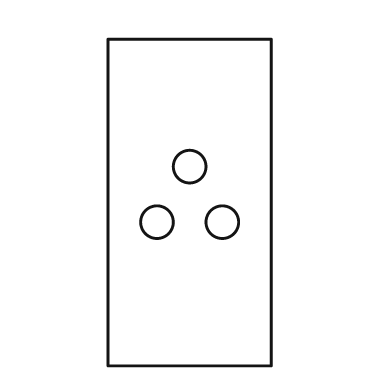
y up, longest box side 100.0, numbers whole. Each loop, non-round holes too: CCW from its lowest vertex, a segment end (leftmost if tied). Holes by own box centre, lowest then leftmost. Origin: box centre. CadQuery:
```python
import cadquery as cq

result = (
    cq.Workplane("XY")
    .moveTo(-25.0, -50.0)
    .lineTo(25.0, -50.0)
    .lineTo(25.0, 50.0)
    .lineTo(-25.0, 50.0)
    .close()
    .moveTo(-10.0, -6.0)
    .circle(5.0)
    .moveTo(10.0, -6.0)
    .circle(5.0)
    .moveTo(0.0, 11.0)
    .circle(5.0)
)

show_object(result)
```